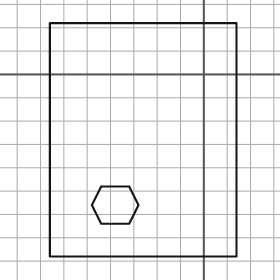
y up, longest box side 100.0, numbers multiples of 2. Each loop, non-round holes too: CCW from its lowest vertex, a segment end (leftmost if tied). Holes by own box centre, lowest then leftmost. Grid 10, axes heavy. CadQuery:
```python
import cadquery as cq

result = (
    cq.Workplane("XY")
    .moveTo(-66.0, -78.0)
    .lineTo(14.0, -78.0)
    .lineTo(14.0, 22.0)
    .lineTo(-66.0, 22.0)
    .close()
    .moveTo(-44.0, -64.0)
    .lineTo(-32.0, -64.0)
    .lineTo(-28.0, -56.0)
    .lineTo(-32.0, -48.0)
    .lineTo(-44.0, -48.0)
    .lineTo(-48.0, -56.0)
    .close()
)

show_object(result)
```